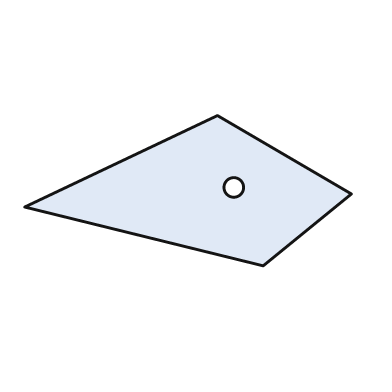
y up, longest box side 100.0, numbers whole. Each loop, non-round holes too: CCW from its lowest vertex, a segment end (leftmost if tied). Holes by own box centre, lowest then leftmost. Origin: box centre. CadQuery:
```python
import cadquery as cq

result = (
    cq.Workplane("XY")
    .moveTo(23.0, -23.0)
    .lineTo(50.0, -1.0)
    .lineTo(9.0, 23.0)
    .lineTo(-50.0, -5.0)
    .close()
    .moveTo(14.0, 1.0)
    .circle(3.0)
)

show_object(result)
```